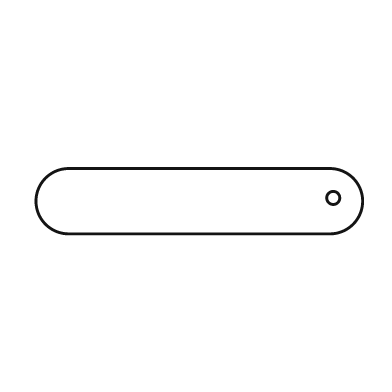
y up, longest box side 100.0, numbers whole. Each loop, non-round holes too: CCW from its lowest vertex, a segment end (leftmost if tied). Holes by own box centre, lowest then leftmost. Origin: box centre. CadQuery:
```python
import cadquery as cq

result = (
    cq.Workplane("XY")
    .moveTo(-40.0, -10.0)
    .lineTo(40.0, -10.0)
    .threePointArc((50.0, 0.0), (40.0, 10.0))
    .lineTo(-40.0, 10.0)
    .threePointArc((-50.0, 0.0), (-40.0, -10.0))
    .close()
    .moveTo(41.0, 1.0)
    .circle(2.0)
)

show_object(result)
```